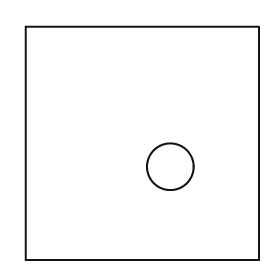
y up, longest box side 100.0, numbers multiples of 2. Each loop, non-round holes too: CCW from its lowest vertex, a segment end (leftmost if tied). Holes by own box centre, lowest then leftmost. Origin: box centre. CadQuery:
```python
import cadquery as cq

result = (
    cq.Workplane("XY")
    .moveTo(-50.0, -50.0)
    .lineTo(50.0, -50.0)
    .lineTo(50.0, 50.0)
    .lineTo(-50.0, 50.0)
    .close()
    .moveTo(12.0, -10.0)
    .circle(10.0)
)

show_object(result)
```